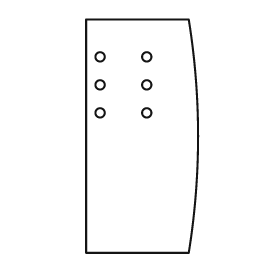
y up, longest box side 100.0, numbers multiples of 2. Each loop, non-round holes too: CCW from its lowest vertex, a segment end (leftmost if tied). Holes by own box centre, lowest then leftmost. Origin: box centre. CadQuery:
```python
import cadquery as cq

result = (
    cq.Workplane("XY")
    .moveTo(-24.0, -50.0)
    .lineTo(20.0, -50.0)
    .threePointArc((24.0, 0.0), (20.0, 50.0))
    .lineTo(-24.0, 50.0)
    .close()
    .moveTo(-18.0, 10.0)
    .circle(2.0)
    .moveTo(2.0, 10.0)
    .circle(2.0)
    .moveTo(-18.0, 22.0)
    .circle(2.0)
    .moveTo(2.0, 22.0)
    .circle(2.0)
    .moveTo(-18.0, 34.0)
    .circle(2.0)
    .moveTo(2.0, 34.0)
    .circle(2.0)
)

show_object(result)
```